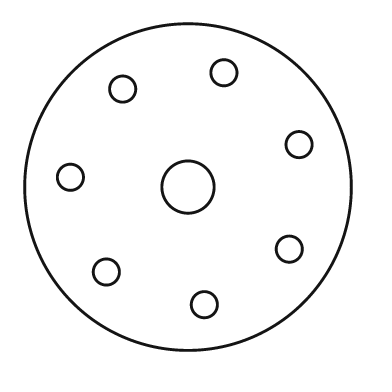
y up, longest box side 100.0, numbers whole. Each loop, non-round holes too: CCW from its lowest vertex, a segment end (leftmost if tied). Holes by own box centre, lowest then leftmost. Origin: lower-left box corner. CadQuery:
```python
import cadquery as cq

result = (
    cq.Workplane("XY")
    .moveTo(50.0, 50.0)
    .circle(50.0)
    .moveTo(55.0, 14.0)
    .circle(4.0)
    .moveTo(25.0, 24.0)
    .circle(4.0)
    .moveTo(81.0, 31.0)
    .circle(4.0)
    .moveTo(50.0, 50.0)
    .circle(8.0)
    .moveTo(14.0, 53.0)
    .circle(4.0)
    .moveTo(84.0, 63.0)
    .circle(4.0)
    .moveTo(30.0, 80.0)
    .circle(4.0)
    .moveTo(61.0, 85.0)
    .circle(4.0)
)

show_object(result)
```